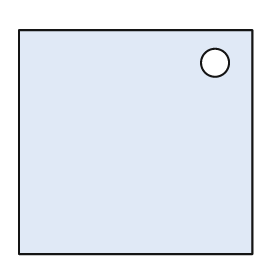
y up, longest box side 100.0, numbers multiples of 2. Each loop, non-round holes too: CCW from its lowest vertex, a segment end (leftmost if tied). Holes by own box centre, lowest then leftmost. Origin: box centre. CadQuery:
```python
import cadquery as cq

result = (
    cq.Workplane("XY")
    .moveTo(-50.0, -48.0)
    .lineTo(50.0, -48.0)
    .lineTo(50.0, 48.0)
    .lineTo(-50.0, 48.0)
    .close()
    .moveTo(34.0, 34.0)
    .circle(6.0)
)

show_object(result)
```